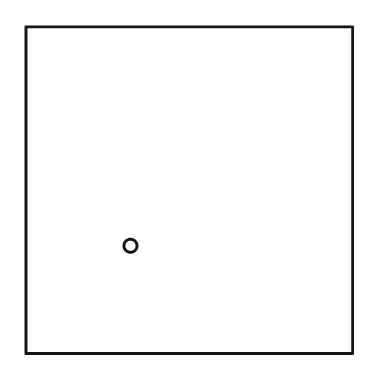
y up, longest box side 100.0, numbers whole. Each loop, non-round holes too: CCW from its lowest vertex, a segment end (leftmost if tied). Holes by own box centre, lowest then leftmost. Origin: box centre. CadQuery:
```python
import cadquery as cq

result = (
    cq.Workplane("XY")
    .moveTo(-50.0, -50.0)
    .lineTo(50.0, -50.0)
    .lineTo(50.0, 50.0)
    .lineTo(-50.0, 50.0)
    .close()
    .moveTo(-18.0, -17.0)
    .circle(2.0)
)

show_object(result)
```